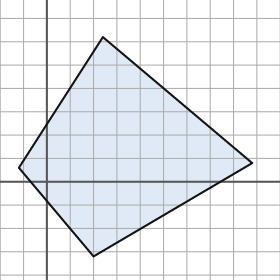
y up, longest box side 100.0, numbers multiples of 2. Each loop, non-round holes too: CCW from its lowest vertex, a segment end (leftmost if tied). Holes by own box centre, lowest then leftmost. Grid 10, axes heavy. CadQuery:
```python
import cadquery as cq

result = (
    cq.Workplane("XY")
    .moveTo(20.0, -32.0)
    .lineTo(88.0, 8.0)
    .lineTo(24.0, 62.0)
    .lineTo(-12.0, 6.0)
    .close()
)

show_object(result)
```